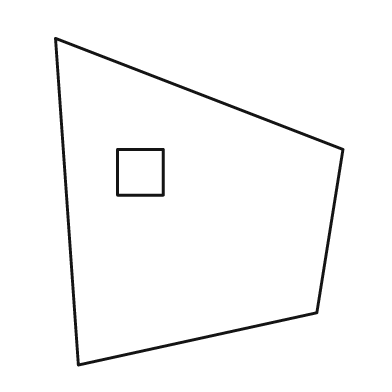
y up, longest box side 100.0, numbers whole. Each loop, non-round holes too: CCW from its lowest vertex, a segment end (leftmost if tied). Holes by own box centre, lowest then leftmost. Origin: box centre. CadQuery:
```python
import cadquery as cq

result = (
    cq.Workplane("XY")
    .moveTo(-37.0, -50.0)
    .lineTo(36.0, -34.0)
    .lineTo(44.0, 16.0)
    .lineTo(-44.0, 50.0)
    .close()
    .moveTo(-25.0, 2.0)
    .lineTo(-11.0, 2.0)
    .lineTo(-11.0, 16.0)
    .lineTo(-25.0, 16.0)
    .close()
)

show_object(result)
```